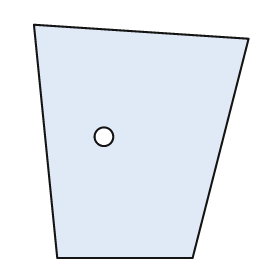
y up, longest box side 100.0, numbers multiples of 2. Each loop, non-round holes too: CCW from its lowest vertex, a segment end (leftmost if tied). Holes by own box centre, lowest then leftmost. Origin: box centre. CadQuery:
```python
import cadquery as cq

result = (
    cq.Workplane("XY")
    .moveTo(-36.0, -50.0)
    .lineTo(22.0, -50.0)
    .lineTo(46.0, 44.0)
    .lineTo(-46.0, 50.0)
    .close()
    .moveTo(-16.0, 2.0)
    .circle(4.0)
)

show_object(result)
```